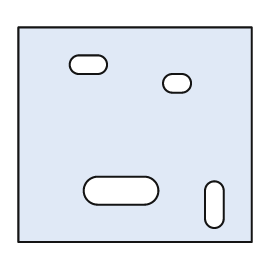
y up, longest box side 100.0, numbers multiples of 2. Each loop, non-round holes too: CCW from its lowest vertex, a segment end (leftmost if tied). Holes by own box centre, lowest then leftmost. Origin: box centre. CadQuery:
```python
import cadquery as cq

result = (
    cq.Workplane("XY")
    .moveTo(-50.0, -46.0)
    .lineTo(50.0, -46.0)
    .lineTo(50.0, 46.0)
    .lineTo(-50.0, 46.0)
    .close()
    .moveTo(30.0, -36.0)
    .threePointArc((34.0, -40.0), (38.0, -36.0))
    .lineTo(38.0, -24.0)
    .threePointArc((34.0, -20.0), (30.0, -24.0))
    .close()
    .moveTo(-16.0, -30.0)
    .lineTo(4.0, -30.0)
    .threePointArc((10.0, -24.0), (4.0, -18.0))
    .lineTo(-16.0, -18.0)
    .threePointArc((-22.0, -24.0), (-16.0, -30.0))
    .close()
    .moveTo(16.0, 18.0)
    .lineTo(20.0, 18.0)
    .threePointArc((24.0, 22.0), (20.0, 26.0))
    .lineTo(16.0, 26.0)
    .threePointArc((12.0, 22.0), (16.0, 18.0))
    .close()
    .moveTo(-24.0, 26.0)
    .lineTo(-16.0, 26.0)
    .threePointArc((-12.0, 30.0), (-16.0, 34.0))
    .lineTo(-24.0, 34.0)
    .threePointArc((-28.0, 30.0), (-24.0, 26.0))
    .close()
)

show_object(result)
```